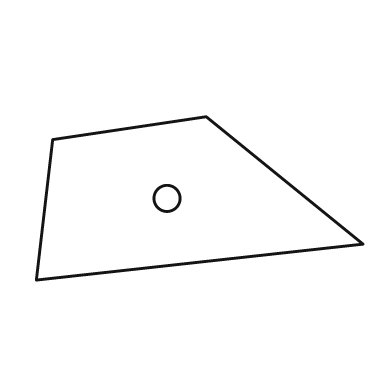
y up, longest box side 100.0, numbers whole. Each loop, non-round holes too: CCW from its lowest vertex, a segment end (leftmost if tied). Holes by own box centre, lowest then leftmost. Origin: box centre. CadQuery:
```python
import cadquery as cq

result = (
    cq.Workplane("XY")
    .moveTo(-50.0, -25.0)
    .lineTo(50.0, -14.0)
    .lineTo(2.0, 25.0)
    .lineTo(-45.0, 18.0)
    .close()
    .moveTo(-10.0, 0.0)
    .circle(4.0)
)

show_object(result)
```